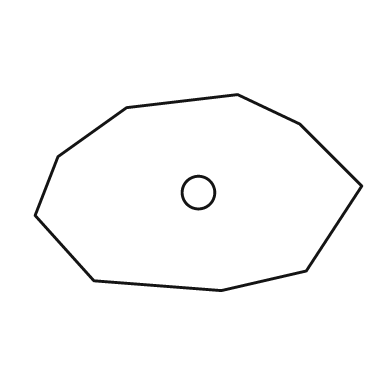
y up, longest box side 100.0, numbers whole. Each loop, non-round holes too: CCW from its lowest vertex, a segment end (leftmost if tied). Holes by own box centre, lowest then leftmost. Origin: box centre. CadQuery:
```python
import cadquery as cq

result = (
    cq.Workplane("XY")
    .moveTo(7.0, -30.0)
    .lineTo(33.0, -24.0)
    .lineTo(50.0, 2.0)
    .lineTo(31.0, 21.0)
    .lineTo(12.0, 30.0)
    .lineTo(-22.0, 26.0)
    .lineTo(-43.0, 11.0)
    .lineTo(-50.0, -7.0)
    .lineTo(-32.0, -27.0)
    .close()
    .moveTo(0.0, 0.0)
    .circle(5.0)
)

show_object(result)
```